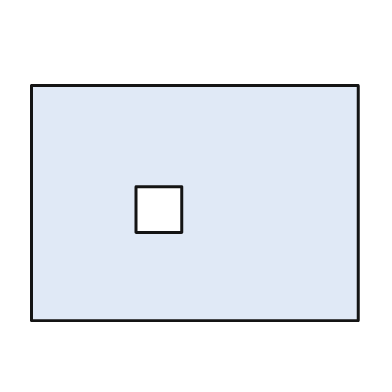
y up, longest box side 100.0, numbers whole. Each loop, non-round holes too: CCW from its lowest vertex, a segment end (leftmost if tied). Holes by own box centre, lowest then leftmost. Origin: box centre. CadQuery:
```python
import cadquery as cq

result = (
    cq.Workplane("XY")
    .moveTo(-50.0, -36.0)
    .lineTo(50.0, -36.0)
    .lineTo(50.0, 36.0)
    .lineTo(-50.0, 36.0)
    .close()
    .moveTo(-18.0, -9.0)
    .lineTo(-4.0, -9.0)
    .lineTo(-4.0, 5.0)
    .lineTo(-18.0, 5.0)
    .close()
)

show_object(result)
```